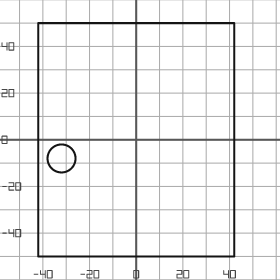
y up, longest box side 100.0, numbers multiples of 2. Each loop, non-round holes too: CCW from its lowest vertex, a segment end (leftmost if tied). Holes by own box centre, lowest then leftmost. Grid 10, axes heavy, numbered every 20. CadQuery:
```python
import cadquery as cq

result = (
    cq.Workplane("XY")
    .moveTo(-42.0, -50.0)
    .lineTo(42.0, -50.0)
    .lineTo(42.0, 50.0)
    .lineTo(-42.0, 50.0)
    .close()
    .moveTo(-32.0, -8.0)
    .circle(6.0)
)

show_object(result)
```